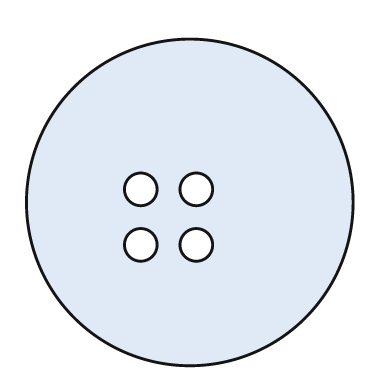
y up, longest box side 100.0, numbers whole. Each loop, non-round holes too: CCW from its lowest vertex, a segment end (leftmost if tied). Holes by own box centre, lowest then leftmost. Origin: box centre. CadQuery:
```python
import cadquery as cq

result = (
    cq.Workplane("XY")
    .moveTo(0.0, 0.0)
    .circle(50.0)
    .moveTo(-15.0, -13.0)
    .circle(5.0)
    .moveTo(2.0, -13.0)
    .circle(5.0)
    .moveTo(-15.0, 4.0)
    .circle(5.0)
    .moveTo(2.0, 4.0)
    .circle(5.0)
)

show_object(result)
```